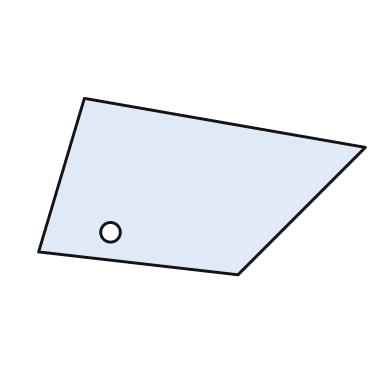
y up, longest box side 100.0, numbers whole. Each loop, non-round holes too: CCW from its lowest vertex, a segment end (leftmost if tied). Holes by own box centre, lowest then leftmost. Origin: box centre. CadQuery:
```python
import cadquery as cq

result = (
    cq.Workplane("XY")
    .moveTo(11.0, -27.0)
    .lineTo(50.0, 12.0)
    .lineTo(-36.0, 27.0)
    .lineTo(-50.0, -20.0)
    .close()
    .moveTo(-28.0, -14.0)
    .circle(3.0)
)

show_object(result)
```